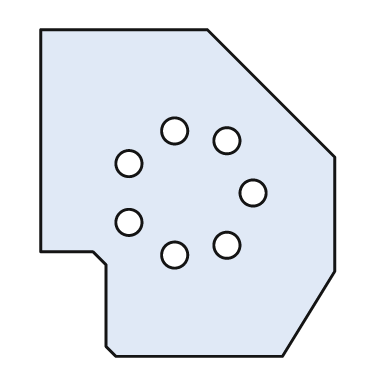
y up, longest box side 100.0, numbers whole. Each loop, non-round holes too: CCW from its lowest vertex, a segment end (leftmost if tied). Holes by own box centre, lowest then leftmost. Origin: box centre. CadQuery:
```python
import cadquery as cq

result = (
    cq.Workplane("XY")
    .moveTo(-22.0, -50.0)
    .lineTo(29.0, -50.0)
    .lineTo(45.0, -24.0)
    .lineTo(45.0, 11.0)
    .lineTo(6.0, 50.0)
    .lineTo(-45.0, 50.0)
    .lineTo(-45.0, -18.0)
    .lineTo(-29.0, -18.0)
    .lineTo(-25.0, -22.0)
    .lineTo(-25.0, -47.0)
    .close()
    .moveTo(-4.0, -19.0)
    .circle(4.0)
    .moveTo(12.0, -16.0)
    .circle(4.0)
    .moveTo(-18.0, -9.0)
    .circle(4.0)
    .moveTo(20.0, 0.0)
    .circle(4.0)
    .moveTo(-18.0, 9.0)
    .circle(4.0)
    .moveTo(12.0, 16.0)
    .circle(4.0)
    .moveTo(-4.0, 19.0)
    .circle(4.0)
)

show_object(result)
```